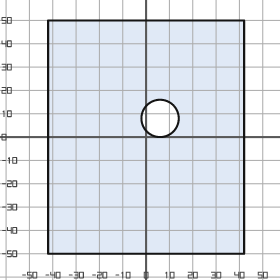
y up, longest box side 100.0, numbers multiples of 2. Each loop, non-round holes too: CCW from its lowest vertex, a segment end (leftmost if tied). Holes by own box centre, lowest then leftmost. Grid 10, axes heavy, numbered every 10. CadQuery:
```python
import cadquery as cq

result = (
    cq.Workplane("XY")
    .moveTo(-42.0, -50.0)
    .lineTo(42.0, -50.0)
    .lineTo(42.0, 50.0)
    .lineTo(-42.0, 50.0)
    .close()
    .moveTo(6.0, 8.0)
    .circle(8.0)
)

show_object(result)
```